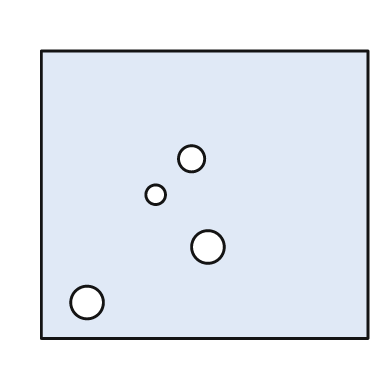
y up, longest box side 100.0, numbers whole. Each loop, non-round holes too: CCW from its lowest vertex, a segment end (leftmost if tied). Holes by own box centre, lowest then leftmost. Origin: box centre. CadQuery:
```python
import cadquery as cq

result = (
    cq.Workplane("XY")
    .moveTo(-50.0, -44.0)
    .lineTo(50.0, -44.0)
    .lineTo(50.0, 44.0)
    .lineTo(-50.0, 44.0)
    .close()
    .moveTo(-36.0, -33.0)
    .circle(5.0)
    .moveTo(1.0, -16.0)
    .circle(5.0)
    .moveTo(-15.0, 0.0)
    .circle(3.0)
    .moveTo(-4.0, 11.0)
    .circle(4.0)
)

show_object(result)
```